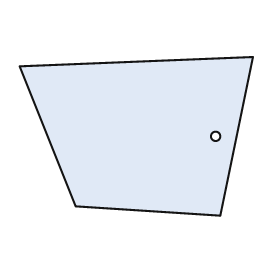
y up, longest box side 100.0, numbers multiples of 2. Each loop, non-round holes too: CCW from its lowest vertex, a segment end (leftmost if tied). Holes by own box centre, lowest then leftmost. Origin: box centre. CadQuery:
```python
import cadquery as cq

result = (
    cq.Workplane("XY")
    .moveTo(36.0, -34.0)
    .lineTo(50.0, 34.0)
    .lineTo(-50.0, 30.0)
    .lineTo(-26.0, -30.0)
    .close()
    .moveTo(34.0, 0.0)
    .circle(2.0)
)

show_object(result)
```